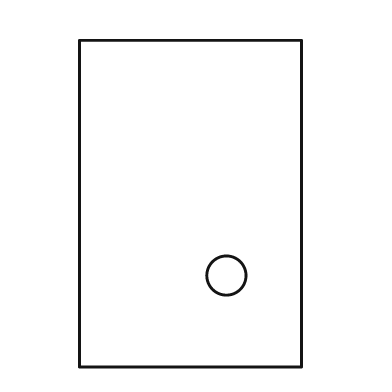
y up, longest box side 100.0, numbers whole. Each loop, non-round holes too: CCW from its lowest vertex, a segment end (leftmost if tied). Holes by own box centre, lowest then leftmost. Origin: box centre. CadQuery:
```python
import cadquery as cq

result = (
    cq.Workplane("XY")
    .moveTo(-34.0, -50.0)
    .lineTo(34.0, -50.0)
    .lineTo(34.0, 50.0)
    .lineTo(-34.0, 50.0)
    .close()
    .moveTo(11.0, -22.0)
    .circle(6.0)
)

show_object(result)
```